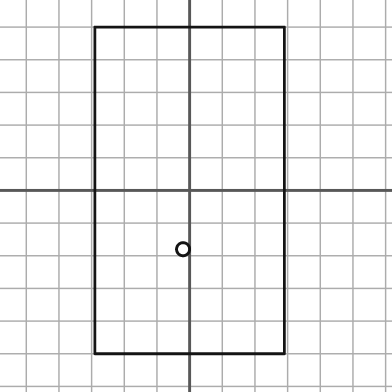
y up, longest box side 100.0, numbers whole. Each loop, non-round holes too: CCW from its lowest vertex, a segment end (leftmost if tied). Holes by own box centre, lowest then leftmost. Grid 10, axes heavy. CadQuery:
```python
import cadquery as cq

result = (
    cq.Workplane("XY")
    .moveTo(-29.0, -50.0)
    .lineTo(29.0, -50.0)
    .lineTo(29.0, 50.0)
    .lineTo(-29.0, 50.0)
    .close()
    .moveTo(-2.0, -18.0)
    .circle(2.0)
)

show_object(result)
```